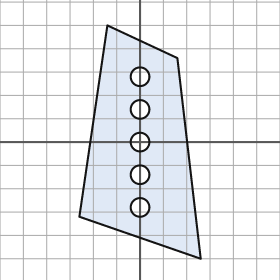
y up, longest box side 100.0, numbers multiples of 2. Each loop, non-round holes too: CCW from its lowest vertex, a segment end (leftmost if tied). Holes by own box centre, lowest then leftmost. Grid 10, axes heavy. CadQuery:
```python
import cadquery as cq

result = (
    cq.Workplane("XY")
    .moveTo(26.0, -50.0)
    .lineTo(16.0, 36.0)
    .lineTo(-14.0, 50.0)
    .lineTo(-26.0, -32.0)
    .close()
    .moveTo(0.0, -28.0)
    .circle(4.0)
    .moveTo(0.0, -14.0)
    .circle(4.0)
    .moveTo(0.0, 0.0)
    .circle(4.0)
    .moveTo(0.0, 14.0)
    .circle(4.0)
    .moveTo(0.0, 28.0)
    .circle(4.0)
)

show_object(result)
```